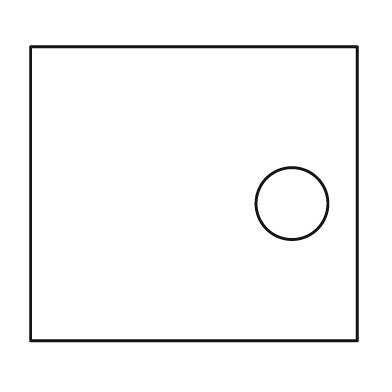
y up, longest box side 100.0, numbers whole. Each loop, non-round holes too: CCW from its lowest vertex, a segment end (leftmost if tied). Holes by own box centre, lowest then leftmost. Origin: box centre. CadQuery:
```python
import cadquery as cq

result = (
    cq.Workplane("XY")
    .moveTo(-50.0, -45.0)
    .lineTo(50.0, -45.0)
    .lineTo(50.0, 45.0)
    .lineTo(-50.0, 45.0)
    .close()
    .moveTo(30.0, -3.0)
    .circle(11.0)
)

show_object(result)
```